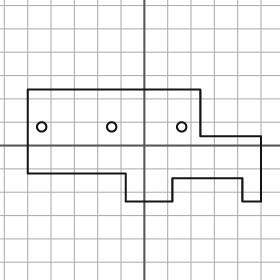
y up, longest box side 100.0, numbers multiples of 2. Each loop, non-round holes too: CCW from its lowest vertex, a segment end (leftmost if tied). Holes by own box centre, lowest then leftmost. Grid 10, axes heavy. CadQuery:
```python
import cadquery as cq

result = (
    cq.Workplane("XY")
    .moveTo(-8.0, -24.0)
    .lineTo(12.0, -24.0)
    .lineTo(12.0, -14.0)
    .lineTo(42.0, -14.0)
    .lineTo(42.0, -24.0)
    .lineTo(50.0, -24.0)
    .lineTo(50.0, 4.0)
    .lineTo(24.0, 4.0)
    .lineTo(24.0, 24.0)
    .lineTo(-50.0, 24.0)
    .lineTo(-50.0, -12.0)
    .lineTo(-8.0, -12.0)
    .close()
    .moveTo(-44.0, 8.0)
    .circle(2.0)
    .moveTo(-14.0, 8.0)
    .circle(2.0)
    .moveTo(16.0, 8.0)
    .circle(2.0)
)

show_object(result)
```